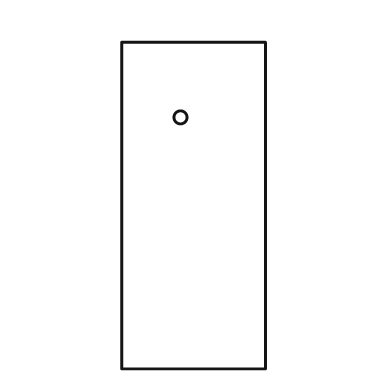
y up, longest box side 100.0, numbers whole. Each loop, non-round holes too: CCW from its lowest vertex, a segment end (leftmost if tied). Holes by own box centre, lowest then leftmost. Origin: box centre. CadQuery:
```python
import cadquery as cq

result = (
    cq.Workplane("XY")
    .moveTo(-22.0, -50.0)
    .lineTo(22.0, -50.0)
    .lineTo(22.0, 50.0)
    .lineTo(-22.0, 50.0)
    .close()
    .moveTo(-4.0, 27.0)
    .circle(2.0)
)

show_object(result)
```